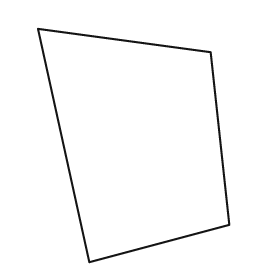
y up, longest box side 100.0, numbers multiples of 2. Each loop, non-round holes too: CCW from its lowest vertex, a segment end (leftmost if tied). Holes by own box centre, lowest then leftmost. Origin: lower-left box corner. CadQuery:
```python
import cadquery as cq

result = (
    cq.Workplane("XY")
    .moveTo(22.0, 0.0)
    .lineTo(82.0, 16.0)
    .lineTo(74.0, 90.0)
    .lineTo(0.0, 100.0)
    .close()
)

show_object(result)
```